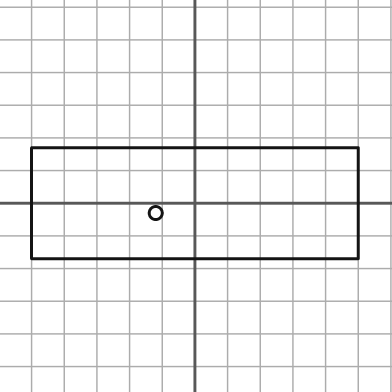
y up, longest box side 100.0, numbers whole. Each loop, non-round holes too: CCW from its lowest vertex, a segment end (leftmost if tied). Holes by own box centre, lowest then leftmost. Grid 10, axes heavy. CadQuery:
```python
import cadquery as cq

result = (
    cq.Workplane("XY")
    .moveTo(-50.0, -17.0)
    .lineTo(50.0, -17.0)
    .lineTo(50.0, 17.0)
    .lineTo(-50.0, 17.0)
    .close()
    .moveTo(-12.0, -3.0)
    .circle(2.0)
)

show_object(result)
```